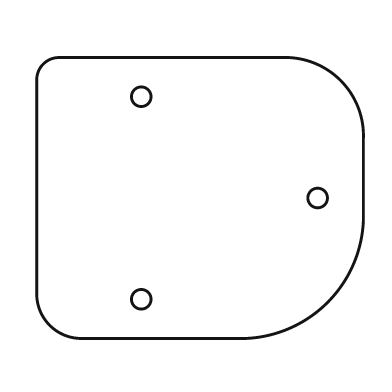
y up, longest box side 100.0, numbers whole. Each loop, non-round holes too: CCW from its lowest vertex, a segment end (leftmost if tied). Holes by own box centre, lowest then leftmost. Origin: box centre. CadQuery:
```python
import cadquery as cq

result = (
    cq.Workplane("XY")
    .moveTo(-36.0, -43.0)
    .lineTo(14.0, -43.0)
    .threePointArc((39.0, -32.0), (50.0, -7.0))
    .lineTo(50.0, 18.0)
    .threePointArc((43.0, 36.0), (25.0, 43.0))
    .lineTo(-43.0, 43.0)
    .threePointArc((-48.0, 41.0), (-50.0, 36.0))
    .lineTo(-50.0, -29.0)
    .threePointArc((-46.0, -39.0), (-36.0, -43.0))
    .close()
    .moveTo(-18.0, -31.0)
    .circle(3.0)
    .moveTo(36.0, 0.0)
    .circle(3.0)
    .moveTo(-18.0, 31.0)
    .circle(3.0)
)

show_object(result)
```